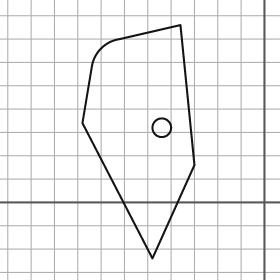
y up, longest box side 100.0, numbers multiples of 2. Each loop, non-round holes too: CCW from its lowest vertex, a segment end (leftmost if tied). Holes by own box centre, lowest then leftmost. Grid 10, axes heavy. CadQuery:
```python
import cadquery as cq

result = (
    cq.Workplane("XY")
    .moveTo(-48.0, -24.0)
    .lineTo(-30.0, 16.0)
    .lineTo(-36.0, 76.0)
    .lineTo(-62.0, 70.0)
    .threePointArc((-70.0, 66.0), (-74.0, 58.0))
    .lineTo(-78.0, 34.0)
    .close()
    .moveTo(-44.0, 32.0)
    .circle(4.0)
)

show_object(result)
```